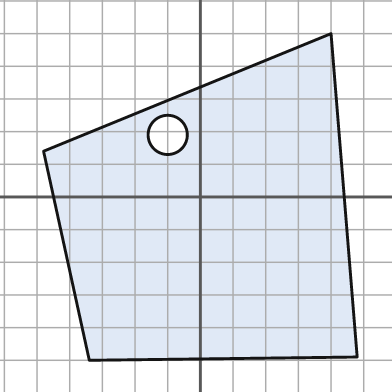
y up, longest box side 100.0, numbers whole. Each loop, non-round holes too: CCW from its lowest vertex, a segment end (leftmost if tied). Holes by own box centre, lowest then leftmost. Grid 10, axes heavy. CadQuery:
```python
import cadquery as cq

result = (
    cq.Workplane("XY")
    .moveTo(-34.0, -50.0)
    .lineTo(48.0, -49.0)
    .lineTo(40.0, 50.0)
    .lineTo(-48.0, 14.0)
    .close()
    .moveTo(-10.0, 19.0)
    .circle(6.0)
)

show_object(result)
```